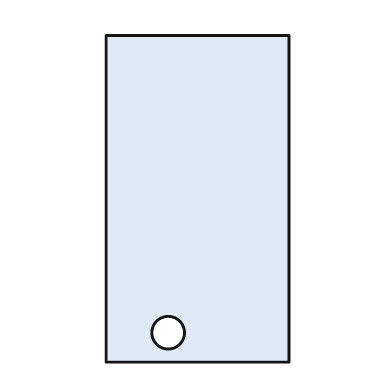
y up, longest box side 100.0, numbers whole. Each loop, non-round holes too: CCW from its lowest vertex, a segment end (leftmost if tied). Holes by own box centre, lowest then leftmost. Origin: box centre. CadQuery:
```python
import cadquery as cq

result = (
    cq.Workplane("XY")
    .moveTo(-28.0, -50.0)
    .lineTo(28.0, -50.0)
    .lineTo(28.0, 50.0)
    .lineTo(-28.0, 50.0)
    .close()
    .moveTo(-9.0, -41.0)
    .circle(5.0)
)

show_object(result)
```